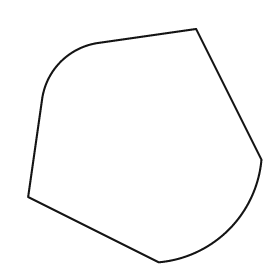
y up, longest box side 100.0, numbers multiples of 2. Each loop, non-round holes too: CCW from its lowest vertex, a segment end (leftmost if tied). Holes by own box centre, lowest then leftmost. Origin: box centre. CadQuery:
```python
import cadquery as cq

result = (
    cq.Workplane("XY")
    .moveTo(6.0, -50.0)
    .threePointArc((36.0, -36.0), (50.0, -6.0))
    .lineTo(22.0, 50.0)
    .lineTo(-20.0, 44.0)
    .threePointArc((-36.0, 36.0), (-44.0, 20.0))
    .lineTo(-50.0, -22.0)
    .close()
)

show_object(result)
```